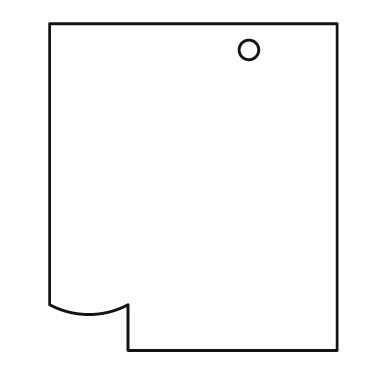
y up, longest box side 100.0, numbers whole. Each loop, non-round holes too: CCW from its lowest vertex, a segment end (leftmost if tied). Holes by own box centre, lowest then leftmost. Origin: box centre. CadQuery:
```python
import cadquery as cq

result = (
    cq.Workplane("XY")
    .moveTo(-20.0, -50.0)
    .lineTo(44.0, -50.0)
    .lineTo(44.0, 50.0)
    .lineTo(-44.0, 50.0)
    .lineTo(-44.0, -36.0)
    .threePointArc((-32.0, -39.0), (-20.0, -36.0))
    .close()
    .moveTo(17.0, 42.0)
    .circle(3.0)
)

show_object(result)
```